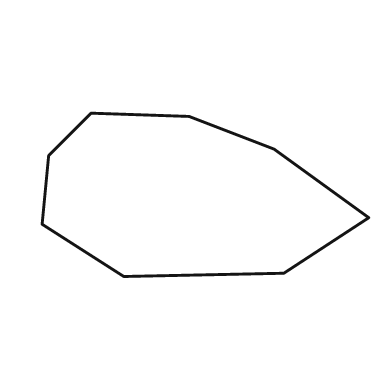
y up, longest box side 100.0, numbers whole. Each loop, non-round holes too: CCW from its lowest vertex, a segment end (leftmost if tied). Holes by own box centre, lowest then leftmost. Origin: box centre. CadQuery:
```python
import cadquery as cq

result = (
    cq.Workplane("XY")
    .moveTo(-25.0, -25.0)
    .lineTo(24.0, -24.0)
    .lineTo(50.0, -7.0)
    .lineTo(21.0, 14.0)
    .lineTo(-5.0, 24.0)
    .lineTo(-35.0, 25.0)
    .lineTo(-48.0, 12.0)
    .lineTo(-50.0, -9.0)
    .close()
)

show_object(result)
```